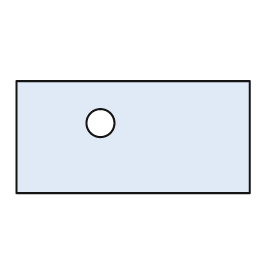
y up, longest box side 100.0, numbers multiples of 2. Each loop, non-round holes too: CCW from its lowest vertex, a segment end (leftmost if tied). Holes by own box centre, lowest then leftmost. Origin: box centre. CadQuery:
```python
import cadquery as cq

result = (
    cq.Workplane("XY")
    .moveTo(-50.0, -24.0)
    .lineTo(50.0, -24.0)
    .lineTo(50.0, 24.0)
    .lineTo(-50.0, 24.0)
    .close()
    .moveTo(-14.0, 6.0)
    .circle(6.0)
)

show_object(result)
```